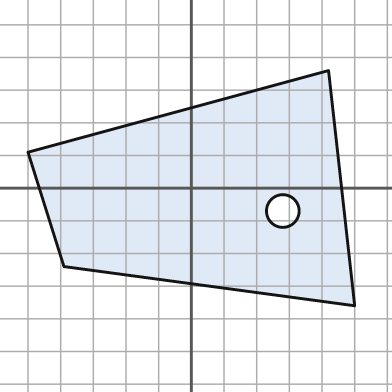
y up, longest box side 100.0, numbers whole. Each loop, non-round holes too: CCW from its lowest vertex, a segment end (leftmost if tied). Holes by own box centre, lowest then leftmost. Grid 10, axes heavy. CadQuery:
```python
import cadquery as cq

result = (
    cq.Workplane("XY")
    .moveTo(50.0, -36.0)
    .lineTo(42.0, 36.0)
    .lineTo(-50.0, 11.0)
    .lineTo(-39.0, -24.0)
    .close()
    .moveTo(28.0, -7.0)
    .circle(5.0)
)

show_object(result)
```